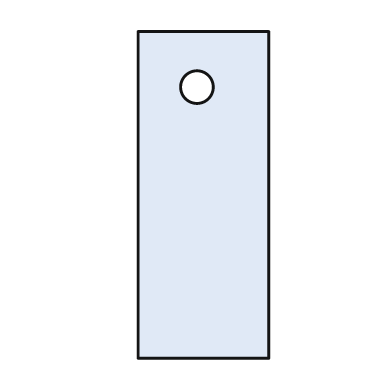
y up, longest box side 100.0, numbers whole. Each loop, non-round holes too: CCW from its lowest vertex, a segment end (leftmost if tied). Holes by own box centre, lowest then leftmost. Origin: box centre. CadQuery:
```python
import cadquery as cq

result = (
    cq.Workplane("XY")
    .moveTo(-20.0, -50.0)
    .lineTo(20.0, -50.0)
    .lineTo(20.0, 50.0)
    .lineTo(-20.0, 50.0)
    .close()
    .moveTo(-2.0, 33.0)
    .circle(5.0)
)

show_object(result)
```